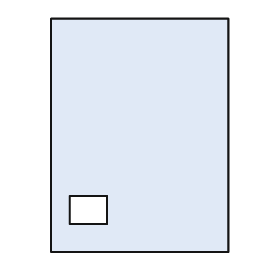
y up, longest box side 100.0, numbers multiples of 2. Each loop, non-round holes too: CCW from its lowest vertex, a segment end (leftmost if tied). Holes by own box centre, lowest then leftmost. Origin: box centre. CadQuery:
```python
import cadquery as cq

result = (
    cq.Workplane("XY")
    .moveTo(-38.0, -50.0)
    .lineTo(38.0, -50.0)
    .lineTo(38.0, 50.0)
    .lineTo(-38.0, 50.0)
    .close()
    .moveTo(-30.0, -38.0)
    .lineTo(-14.0, -38.0)
    .lineTo(-14.0, -26.0)
    .lineTo(-30.0, -26.0)
    .close()
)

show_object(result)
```